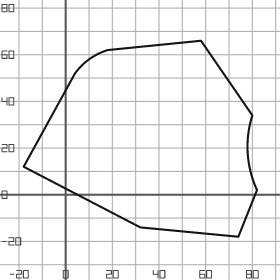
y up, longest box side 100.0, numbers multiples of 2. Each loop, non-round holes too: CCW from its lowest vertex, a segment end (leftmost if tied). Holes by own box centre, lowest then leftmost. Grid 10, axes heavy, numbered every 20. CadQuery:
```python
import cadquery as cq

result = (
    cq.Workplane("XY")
    .moveTo(74.0, -18.0)
    .lineTo(82.0, 2.0)
    .threePointArc((78.0, 18.0), (80.0, 34.0))
    .lineTo(58.0, 66.0)
    .lineTo(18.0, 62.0)
    .threePointArc((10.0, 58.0), (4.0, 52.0))
    .lineTo(-18.0, 12.0)
    .lineTo(32.0, -14.0)
    .close()
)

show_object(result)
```